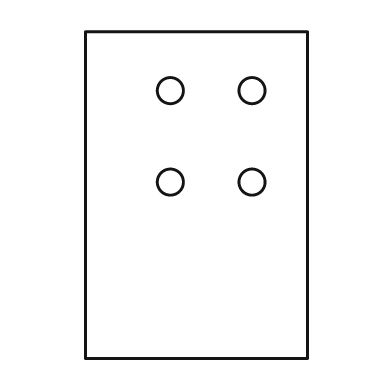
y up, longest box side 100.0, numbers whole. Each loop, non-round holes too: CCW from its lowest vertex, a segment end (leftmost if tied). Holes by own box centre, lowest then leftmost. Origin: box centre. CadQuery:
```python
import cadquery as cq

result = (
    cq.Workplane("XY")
    .moveTo(-34.0, -50.0)
    .lineTo(34.0, -50.0)
    .lineTo(34.0, 50.0)
    .lineTo(-34.0, 50.0)
    .close()
    .moveTo(-8.0, 4.0)
    .circle(4.0)
    .moveTo(17.0, 4.0)
    .circle(4.0)
    .moveTo(-8.0, 32.0)
    .circle(4.0)
    .moveTo(17.0, 32.0)
    .circle(4.0)
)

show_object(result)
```